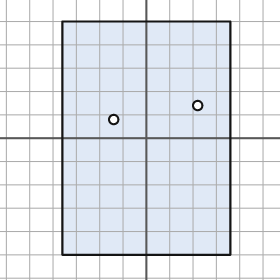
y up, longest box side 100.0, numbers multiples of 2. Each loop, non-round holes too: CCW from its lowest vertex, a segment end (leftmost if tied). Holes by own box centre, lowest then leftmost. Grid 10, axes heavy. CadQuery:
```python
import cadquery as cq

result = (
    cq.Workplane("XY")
    .moveTo(-36.0, -50.0)
    .lineTo(36.0, -50.0)
    .lineTo(36.0, 50.0)
    .lineTo(-36.0, 50.0)
    .close()
    .moveTo(-14.0, 8.0)
    .circle(2.0)
    .moveTo(22.0, 14.0)
    .circle(2.0)
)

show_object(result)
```